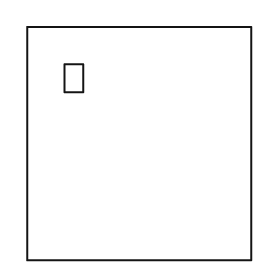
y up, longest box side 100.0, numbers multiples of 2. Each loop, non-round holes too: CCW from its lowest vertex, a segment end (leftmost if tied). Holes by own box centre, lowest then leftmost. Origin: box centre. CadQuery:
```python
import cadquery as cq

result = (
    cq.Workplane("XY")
    .moveTo(-48.0, -50.0)
    .lineTo(48.0, -50.0)
    .lineTo(48.0, 50.0)
    .lineTo(-48.0, 50.0)
    .close()
    .moveTo(-32.0, 22.0)
    .lineTo(-24.0, 22.0)
    .lineTo(-24.0, 34.0)
    .lineTo(-32.0, 34.0)
    .close()
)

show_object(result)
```